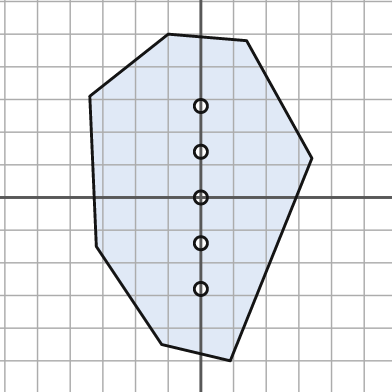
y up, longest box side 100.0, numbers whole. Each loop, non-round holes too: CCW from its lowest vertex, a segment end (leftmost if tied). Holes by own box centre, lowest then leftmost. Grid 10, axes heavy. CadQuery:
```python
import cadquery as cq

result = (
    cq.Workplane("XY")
    .moveTo(9.0, -50.0)
    .lineTo(34.0, 12.0)
    .lineTo(14.0, 48.0)
    .lineTo(-10.0, 50.0)
    .lineTo(-34.0, 31.0)
    .lineTo(-32.0, -15.0)
    .lineTo(-12.0, -45.0)
    .close()
    .moveTo(0.0, -28.0)
    .circle(2.0)
    .moveTo(0.0, -14.0)
    .circle(2.0)
    .moveTo(0.0, 0.0)
    .circle(2.0)
    .moveTo(0.0, 14.0)
    .circle(2.0)
    .moveTo(0.0, 28.0)
    .circle(2.0)
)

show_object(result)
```